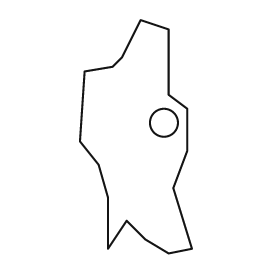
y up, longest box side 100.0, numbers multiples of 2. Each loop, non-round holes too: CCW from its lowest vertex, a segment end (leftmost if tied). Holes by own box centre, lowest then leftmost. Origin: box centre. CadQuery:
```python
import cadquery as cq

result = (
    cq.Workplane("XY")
    .moveTo(14.0, -50.0)
    .lineTo(24.0, -48.0)
    .lineTo(16.0, -22.0)
    .lineTo(22.0, -6.0)
    .lineTo(22.0, 12.0)
    .lineTo(14.0, 18.0)
    .lineTo(14.0, 46.0)
    .lineTo(2.0, 50.0)
    .lineTo(-6.0, 34.0)
    .lineTo(-10.0, 30.0)
    .lineTo(-22.0, 28.0)
    .lineTo(-24.0, -2.0)
    .lineTo(-16.0, -12.0)
    .lineTo(-12.0, -26.0)
    .lineTo(-12.0, -48.0)
    .lineTo(-4.0, -36.0)
    .lineTo(4.0, -44.0)
    .close()
    .moveTo(12.0, 6.0)
    .circle(6.0)
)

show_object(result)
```